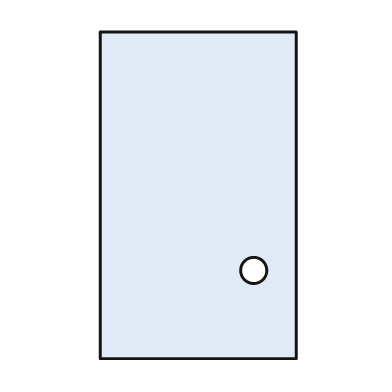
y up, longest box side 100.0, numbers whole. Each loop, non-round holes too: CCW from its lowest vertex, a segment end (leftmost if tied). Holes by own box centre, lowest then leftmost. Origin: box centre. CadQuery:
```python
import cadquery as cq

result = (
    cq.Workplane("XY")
    .moveTo(-30.0, -50.0)
    .lineTo(30.0, -50.0)
    .lineTo(30.0, 50.0)
    .lineTo(-30.0, 50.0)
    .close()
    .moveTo(17.0, -23.0)
    .circle(4.0)
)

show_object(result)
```